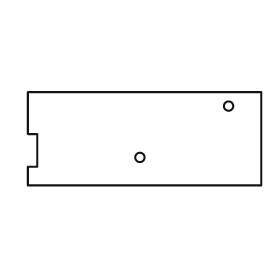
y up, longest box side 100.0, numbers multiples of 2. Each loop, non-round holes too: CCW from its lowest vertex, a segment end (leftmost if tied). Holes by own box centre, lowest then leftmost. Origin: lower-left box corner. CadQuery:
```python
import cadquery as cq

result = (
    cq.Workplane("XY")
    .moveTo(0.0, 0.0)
    .lineTo(100.0, 0.0)
    .lineTo(100.0, 40.0)
    .lineTo(0.0, 40.0)
    .lineTo(0.0, 22.0)
    .lineTo(4.0, 22.0)
    .lineTo(4.0, 8.0)
    .lineTo(0.0, 8.0)
    .close()
    .moveTo(48.0, 12.0)
    .circle(2.0)
    .moveTo(86.0, 34.0)
    .circle(2.0)
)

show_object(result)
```